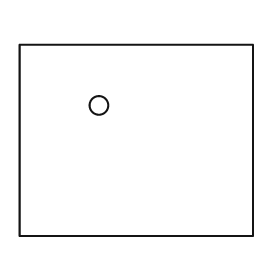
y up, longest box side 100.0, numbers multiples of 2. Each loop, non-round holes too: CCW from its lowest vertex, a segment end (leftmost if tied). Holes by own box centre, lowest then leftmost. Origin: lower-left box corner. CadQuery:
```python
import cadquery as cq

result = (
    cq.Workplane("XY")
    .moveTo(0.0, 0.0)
    .lineTo(100.0, 0.0)
    .lineTo(100.0, 82.0)
    .lineTo(0.0, 82.0)
    .close()
    .moveTo(34.0, 56.0)
    .circle(4.0)
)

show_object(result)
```